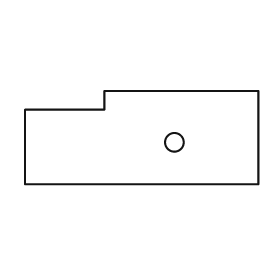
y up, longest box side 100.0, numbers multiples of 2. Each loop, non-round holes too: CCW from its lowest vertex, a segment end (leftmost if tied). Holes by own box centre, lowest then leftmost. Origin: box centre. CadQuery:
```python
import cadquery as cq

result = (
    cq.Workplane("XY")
    .moveTo(-50.0, -20.0)
    .lineTo(50.0, -20.0)
    .lineTo(50.0, 20.0)
    .lineTo(-16.0, 20.0)
    .lineTo(-16.0, 12.0)
    .lineTo(-50.0, 12.0)
    .close()
    .moveTo(14.0, -2.0)
    .circle(4.0)
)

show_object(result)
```